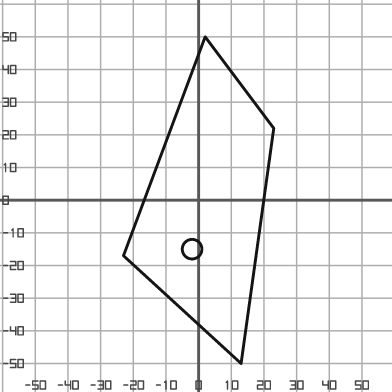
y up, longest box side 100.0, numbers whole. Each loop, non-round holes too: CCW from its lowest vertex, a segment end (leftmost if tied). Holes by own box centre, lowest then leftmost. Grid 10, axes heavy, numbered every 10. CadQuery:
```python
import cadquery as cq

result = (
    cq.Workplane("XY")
    .moveTo(13.0, -50.0)
    .lineTo(23.0, 22.0)
    .lineTo(2.0, 50.0)
    .lineTo(-23.0, -17.0)
    .close()
    .moveTo(-2.0, -15.0)
    .circle(3.0)
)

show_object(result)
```